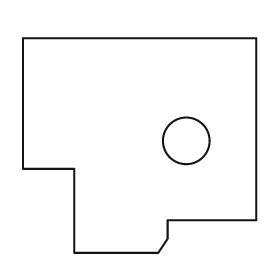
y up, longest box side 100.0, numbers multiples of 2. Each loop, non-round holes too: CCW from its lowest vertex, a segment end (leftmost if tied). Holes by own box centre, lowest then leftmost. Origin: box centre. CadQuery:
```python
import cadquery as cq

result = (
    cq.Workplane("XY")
    .moveTo(-28.0, -46.0)
    .lineTo(8.0, -46.0)
    .lineTo(12.0, -40.0)
    .lineTo(12.0, -32.0)
    .lineTo(50.0, -32.0)
    .lineTo(50.0, 46.0)
    .lineTo(-50.0, 46.0)
    .lineTo(-50.0, -10.0)
    .lineTo(-28.0, -10.0)
    .close()
    .moveTo(20.0, 2.0)
    .circle(10.0)
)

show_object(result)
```